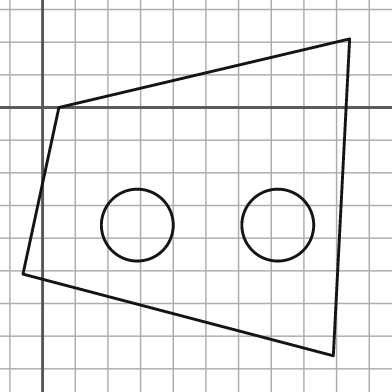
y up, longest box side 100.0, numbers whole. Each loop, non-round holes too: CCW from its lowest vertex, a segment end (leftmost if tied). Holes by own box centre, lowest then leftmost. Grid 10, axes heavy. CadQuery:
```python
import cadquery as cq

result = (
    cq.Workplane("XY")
    .moveTo(89.0, -76.0)
    .lineTo(94.0, 21.0)
    .lineTo(5.0, 0.0)
    .lineTo(-6.0, -51.0)
    .close()
    .moveTo(29.0, -36.0)
    .circle(11.0)
    .moveTo(72.0, -36.0)
    .circle(11.0)
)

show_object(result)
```